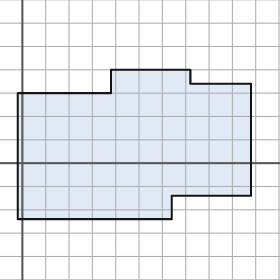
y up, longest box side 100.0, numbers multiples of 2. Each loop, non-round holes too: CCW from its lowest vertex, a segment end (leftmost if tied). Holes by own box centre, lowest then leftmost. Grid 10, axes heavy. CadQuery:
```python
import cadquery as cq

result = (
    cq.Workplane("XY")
    .moveTo(-2.0, -24.0)
    .lineTo(64.0, -24.0)
    .lineTo(64.0, -14.0)
    .lineTo(98.0, -14.0)
    .lineTo(98.0, 34.0)
    .lineTo(72.0, 34.0)
    .lineTo(72.0, 40.0)
    .lineTo(38.0, 40.0)
    .lineTo(38.0, 30.0)
    .lineTo(-2.0, 30.0)
    .close()
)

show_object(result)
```